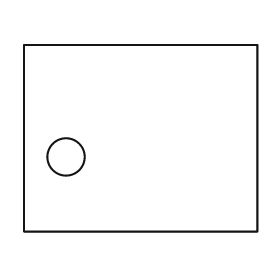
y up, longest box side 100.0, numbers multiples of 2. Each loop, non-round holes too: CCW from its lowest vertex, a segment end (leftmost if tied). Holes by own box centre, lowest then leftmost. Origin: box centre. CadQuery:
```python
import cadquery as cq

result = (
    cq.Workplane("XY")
    .moveTo(-50.0, -40.0)
    .lineTo(50.0, -40.0)
    .lineTo(50.0, 40.0)
    .lineTo(-50.0, 40.0)
    .close()
    .moveTo(-32.0, -8.0)
    .circle(8.0)
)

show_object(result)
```